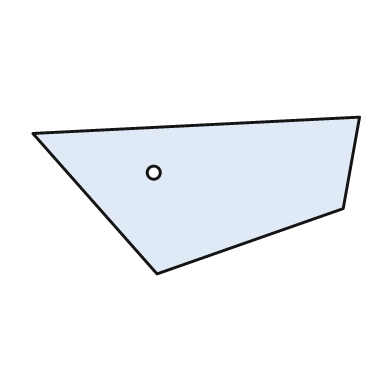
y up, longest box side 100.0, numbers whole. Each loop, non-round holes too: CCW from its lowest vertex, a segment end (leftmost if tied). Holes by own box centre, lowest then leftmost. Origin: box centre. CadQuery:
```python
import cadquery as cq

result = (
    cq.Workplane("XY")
    .moveTo(-12.0, -24.0)
    .lineTo(45.0, -4.0)
    .lineTo(50.0, 24.0)
    .lineTo(-50.0, 19.0)
    .close()
    .moveTo(-13.0, 7.0)
    .circle(2.0)
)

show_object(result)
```